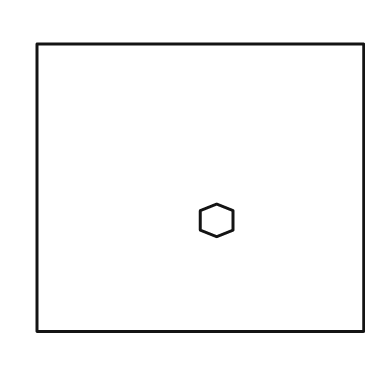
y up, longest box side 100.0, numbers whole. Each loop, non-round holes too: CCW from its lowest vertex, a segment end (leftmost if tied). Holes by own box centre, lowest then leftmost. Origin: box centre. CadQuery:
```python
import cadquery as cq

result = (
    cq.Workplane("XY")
    .moveTo(-50.0, -44.0)
    .lineTo(50.0, -44.0)
    .lineTo(50.0, 44.0)
    .lineTo(-50.0, 44.0)
    .close()
    .moveTo(5.0, -15.0)
    .lineTo(10.0, -13.0)
    .lineTo(10.0, -7.0)
    .lineTo(5.0, -5.0)
    .lineTo(0.0, -7.0)
    .lineTo(0.0, -13.0)
    .close()
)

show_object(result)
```